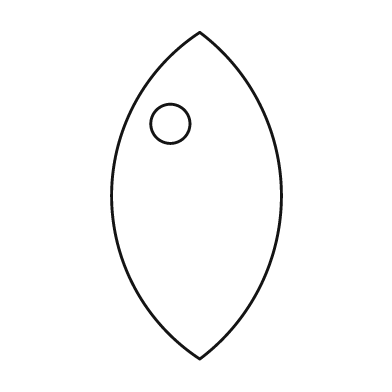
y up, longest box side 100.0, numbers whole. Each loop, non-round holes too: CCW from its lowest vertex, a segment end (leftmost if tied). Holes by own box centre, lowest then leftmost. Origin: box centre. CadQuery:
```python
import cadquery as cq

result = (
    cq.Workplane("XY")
    .moveTo(1.0, -50.0)
    .threePointArc((26.0, 0.0), (1.0, 50.0))
    .threePointArc((-26.0, 0.0), (1.0, -50.0))
    .close()
    .moveTo(-8.0, 22.0)
    .circle(6.0)
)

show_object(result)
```